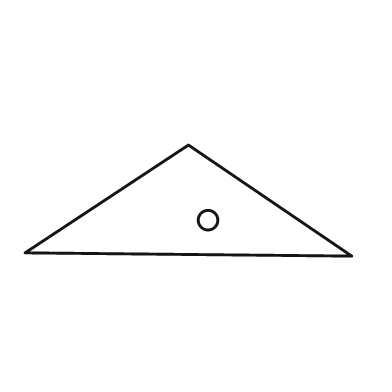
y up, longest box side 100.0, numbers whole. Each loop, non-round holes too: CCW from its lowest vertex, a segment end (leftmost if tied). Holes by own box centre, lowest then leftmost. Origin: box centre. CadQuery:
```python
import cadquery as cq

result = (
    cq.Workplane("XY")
    .moveTo(50.0, -17.0)
    .lineTo(0.0, 17.0)
    .lineTo(-50.0, -16.0)
    .close()
    .moveTo(6.0, -6.0)
    .circle(3.0)
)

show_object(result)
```